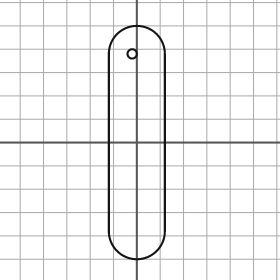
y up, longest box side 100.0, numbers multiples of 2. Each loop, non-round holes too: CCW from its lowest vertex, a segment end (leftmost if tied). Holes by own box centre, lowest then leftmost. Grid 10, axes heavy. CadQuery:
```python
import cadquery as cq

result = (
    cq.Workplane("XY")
    .moveTo(-12.0, -38.0)
    .threePointArc((0.0, -50.0), (12.0, -38.0))
    .lineTo(12.0, 38.0)
    .threePointArc((0.0, 50.0), (-12.0, 38.0))
    .close()
    .moveTo(-2.0, 38.0)
    .circle(2.0)
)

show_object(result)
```